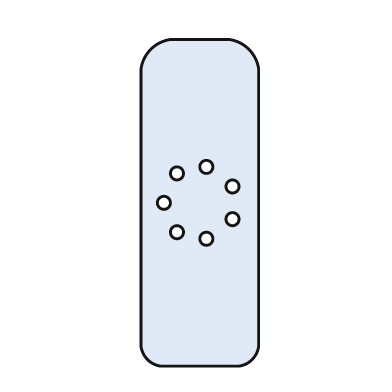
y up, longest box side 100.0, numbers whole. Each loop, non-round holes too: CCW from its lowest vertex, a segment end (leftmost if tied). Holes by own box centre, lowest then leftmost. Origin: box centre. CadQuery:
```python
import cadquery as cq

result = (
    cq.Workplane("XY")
    .moveTo(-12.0, -50.0)
    .lineTo(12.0, -50.0)
    .threePointArc((16.0, -48.0), (18.0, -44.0))
    .lineTo(18.0, 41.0)
    .threePointArc((15.0, 47.0), (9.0, 50.0))
    .lineTo(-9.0, 50.0)
    .threePointArc((-15.0, 47.0), (-18.0, 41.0))
    .lineTo(-18.0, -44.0)
    .threePointArc((-16.0, -48.0), (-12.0, -50.0))
    .close()
    .moveTo(2.0, -11.0)
    .circle(2.0)
    .moveTo(-7.0, -9.0)
    .circle(2.0)
    .moveTo(10.0, -5.0)
    .circle(2.0)
    .moveTo(-11.0, 0.0)
    .circle(2.0)
    .moveTo(10.0, 5.0)
    .circle(2.0)
    .moveTo(-7.0, 9.0)
    .circle(2.0)
    .moveTo(2.0, 11.0)
    .circle(2.0)
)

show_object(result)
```